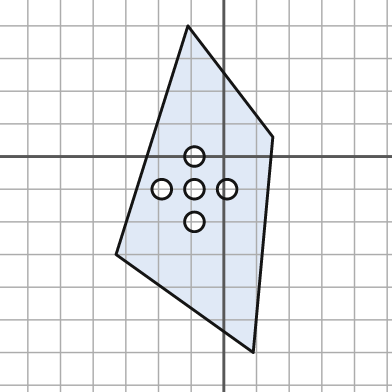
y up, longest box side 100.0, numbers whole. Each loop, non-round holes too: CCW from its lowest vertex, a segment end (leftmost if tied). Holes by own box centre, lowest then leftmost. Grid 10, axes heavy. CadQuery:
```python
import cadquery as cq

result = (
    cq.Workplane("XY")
    .moveTo(9.0, -60.0)
    .lineTo(15.0, 6.0)
    .lineTo(-11.0, 40.0)
    .lineTo(-33.0, -30.0)
    .close()
    .moveTo(-9.0, -20.0)
    .circle(3.0)
    .moveTo(-19.0, -10.0)
    .circle(3.0)
    .moveTo(-9.0, -10.0)
    .circle(3.0)
    .moveTo(1.0, -10.0)
    .circle(3.0)
    .moveTo(-9.0, 0.0)
    .circle(3.0)
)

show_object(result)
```